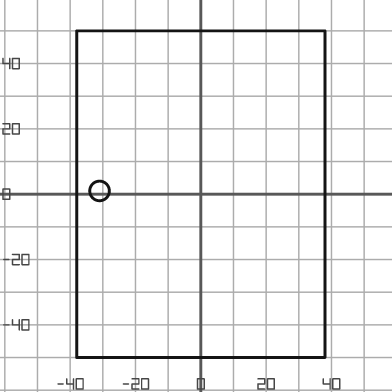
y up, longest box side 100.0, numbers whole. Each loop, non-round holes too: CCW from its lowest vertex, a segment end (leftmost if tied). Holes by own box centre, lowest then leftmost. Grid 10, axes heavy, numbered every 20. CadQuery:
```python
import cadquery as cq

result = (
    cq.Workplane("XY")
    .moveTo(-38.0, -50.0)
    .lineTo(38.0, -50.0)
    .lineTo(38.0, 50.0)
    .lineTo(-38.0, 50.0)
    .close()
    .moveTo(-31.0, 1.0)
    .circle(3.0)
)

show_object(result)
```